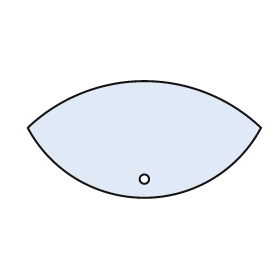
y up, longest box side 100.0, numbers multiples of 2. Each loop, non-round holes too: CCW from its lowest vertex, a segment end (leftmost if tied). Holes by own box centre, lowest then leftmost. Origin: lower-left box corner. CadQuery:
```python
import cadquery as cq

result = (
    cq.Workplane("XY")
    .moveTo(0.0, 30.0)
    .threePointArc((50.0, 0.0), (100.0, 30.0))
    .threePointArc((50.0, 50.0), (0.0, 30.0))
    .close()
    .moveTo(50.0, 8.0)
    .circle(2.0)
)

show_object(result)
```